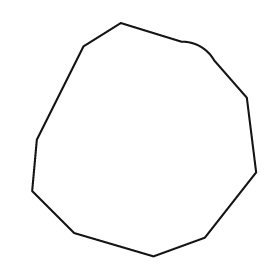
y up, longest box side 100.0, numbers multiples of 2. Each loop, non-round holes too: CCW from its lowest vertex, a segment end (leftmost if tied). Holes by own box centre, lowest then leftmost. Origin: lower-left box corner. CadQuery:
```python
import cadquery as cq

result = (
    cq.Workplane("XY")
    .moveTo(52.0, 0.0)
    .lineTo(74.0, 8.0)
    .lineTo(96.0, 36.0)
    .lineTo(92.0, 68.0)
    .lineTo(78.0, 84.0)
    .threePointArc((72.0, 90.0), (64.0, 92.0))
    .lineTo(38.0, 100.0)
    .lineTo(22.0, 90.0)
    .lineTo(2.0, 50.0)
    .lineTo(0.0, 28.0)
    .lineTo(18.0, 10.0)
    .close()
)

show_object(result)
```